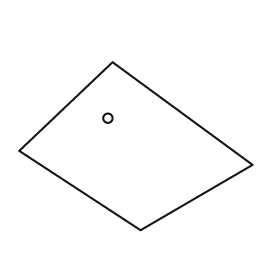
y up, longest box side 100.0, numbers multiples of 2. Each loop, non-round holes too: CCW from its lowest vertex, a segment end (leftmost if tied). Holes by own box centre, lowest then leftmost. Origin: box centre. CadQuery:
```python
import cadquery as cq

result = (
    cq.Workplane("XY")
    .moveTo(2.0, -36.0)
    .lineTo(50.0, -8.0)
    .lineTo(-10.0, 36.0)
    .lineTo(-50.0, -2.0)
    .close()
    .moveTo(-12.0, 12.0)
    .circle(2.0)
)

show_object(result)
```